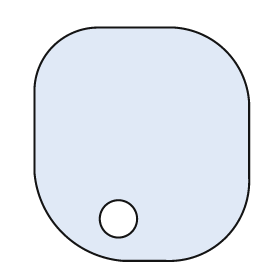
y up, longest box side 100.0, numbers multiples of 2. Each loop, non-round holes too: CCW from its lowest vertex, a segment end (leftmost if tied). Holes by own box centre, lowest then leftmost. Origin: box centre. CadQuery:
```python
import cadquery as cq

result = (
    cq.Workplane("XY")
    .moveTo(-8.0, -50.0)
    .lineTo(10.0, -50.0)
    .threePointArc((36.0, -40.0), (46.0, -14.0))
    .lineTo(46.0, 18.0)
    .threePointArc((36.0, 40.0), (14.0, 50.0))
    .lineTo(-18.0, 50.0)
    .threePointArc((-38.0, 42.0), (-46.0, 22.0))
    .lineTo(-46.0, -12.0)
    .threePointArc((-34.0, -38.0), (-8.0, -50.0))
    .close()
    .moveTo(-10.0, -32.0)
    .circle(8.0)
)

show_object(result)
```